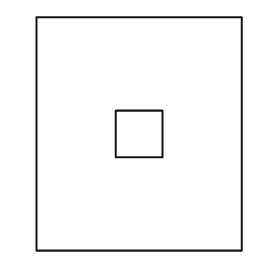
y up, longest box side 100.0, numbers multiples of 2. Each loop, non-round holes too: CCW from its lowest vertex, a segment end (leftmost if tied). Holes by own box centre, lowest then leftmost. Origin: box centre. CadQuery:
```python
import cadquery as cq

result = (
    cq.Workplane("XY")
    .moveTo(-44.0, -50.0)
    .lineTo(44.0, -50.0)
    .lineTo(44.0, 50.0)
    .lineTo(-44.0, 50.0)
    .close()
    .moveTo(-10.0, -10.0)
    .lineTo(10.0, -10.0)
    .lineTo(10.0, 10.0)
    .lineTo(-10.0, 10.0)
    .close()
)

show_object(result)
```